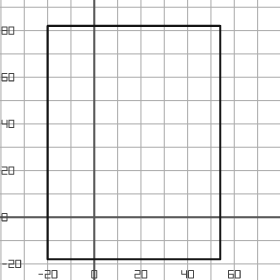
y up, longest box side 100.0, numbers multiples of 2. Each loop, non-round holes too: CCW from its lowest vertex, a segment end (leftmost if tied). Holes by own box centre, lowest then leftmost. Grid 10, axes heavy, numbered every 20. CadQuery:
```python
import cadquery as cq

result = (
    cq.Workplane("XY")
    .moveTo(-20.0, -18.0)
    .lineTo(54.0, -18.0)
    .lineTo(54.0, 82.0)
    .lineTo(-20.0, 82.0)
    .close()
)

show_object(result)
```